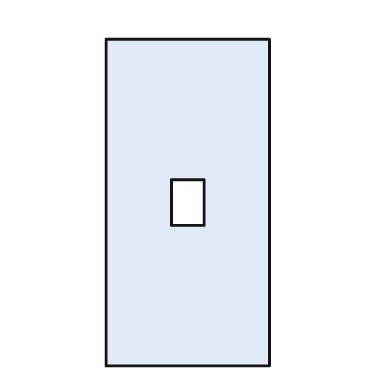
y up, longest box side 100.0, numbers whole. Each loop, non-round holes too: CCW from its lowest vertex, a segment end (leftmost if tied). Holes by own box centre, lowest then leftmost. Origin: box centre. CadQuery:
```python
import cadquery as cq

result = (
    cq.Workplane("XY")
    .moveTo(-25.0, -50.0)
    .lineTo(25.0, -50.0)
    .lineTo(25.0, 50.0)
    .lineTo(-25.0, 50.0)
    .close()
    .moveTo(-5.0, -7.0)
    .lineTo(5.0, -7.0)
    .lineTo(5.0, 7.0)
    .lineTo(-5.0, 7.0)
    .close()
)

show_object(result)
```